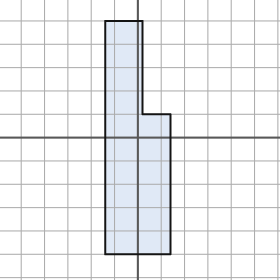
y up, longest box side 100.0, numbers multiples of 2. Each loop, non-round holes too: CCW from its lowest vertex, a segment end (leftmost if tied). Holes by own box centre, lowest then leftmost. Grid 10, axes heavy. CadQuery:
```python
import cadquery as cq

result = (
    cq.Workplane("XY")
    .moveTo(-14.0, -50.0)
    .lineTo(14.0, -50.0)
    .lineTo(14.0, 10.0)
    .lineTo(2.0, 10.0)
    .lineTo(2.0, 50.0)
    .lineTo(-14.0, 50.0)
    .close()
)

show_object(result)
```